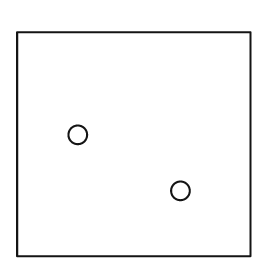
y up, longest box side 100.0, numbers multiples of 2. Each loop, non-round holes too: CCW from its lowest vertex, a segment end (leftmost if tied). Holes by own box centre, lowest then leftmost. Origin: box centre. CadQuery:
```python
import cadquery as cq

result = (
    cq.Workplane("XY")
    .moveTo(-50.0, -48.0)
    .lineTo(50.0, -48.0)
    .lineTo(50.0, 48.0)
    .lineTo(-50.0, 48.0)
    .close()
    .moveTo(20.0, -20.0)
    .circle(4.0)
    .moveTo(-24.0, 4.0)
    .circle(4.0)
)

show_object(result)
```